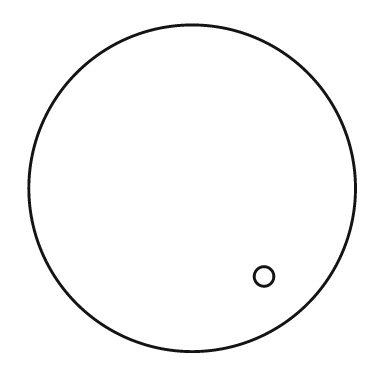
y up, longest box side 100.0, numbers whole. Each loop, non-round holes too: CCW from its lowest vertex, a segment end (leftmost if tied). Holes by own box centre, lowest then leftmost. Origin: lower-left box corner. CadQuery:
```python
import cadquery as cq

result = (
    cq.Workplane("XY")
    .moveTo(50.0, 50.0)
    .circle(50.0)
    .moveTo(72.0, 23.0)
    .circle(3.0)
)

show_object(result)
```